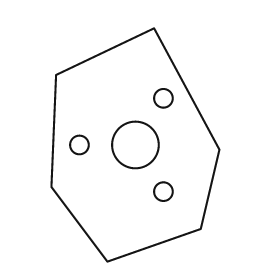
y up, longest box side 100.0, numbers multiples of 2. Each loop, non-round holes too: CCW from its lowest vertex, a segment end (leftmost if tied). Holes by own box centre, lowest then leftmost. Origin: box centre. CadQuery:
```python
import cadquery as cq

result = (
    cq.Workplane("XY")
    .moveTo(-12.0, -50.0)
    .lineTo(28.0, -36.0)
    .lineTo(36.0, -2.0)
    .lineTo(8.0, 50.0)
    .lineTo(-34.0, 30.0)
    .lineTo(-36.0, -18.0)
    .close()
    .moveTo(12.0, -20.0)
    .circle(4.0)
    .moveTo(-24.0, 0.0)
    .circle(4.0)
    .moveTo(0.0, 0.0)
    .circle(10.0)
    .moveTo(12.0, 20.0)
    .circle(4.0)
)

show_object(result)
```